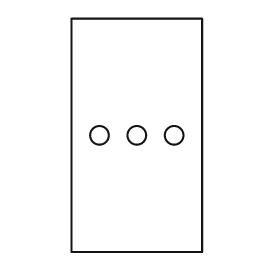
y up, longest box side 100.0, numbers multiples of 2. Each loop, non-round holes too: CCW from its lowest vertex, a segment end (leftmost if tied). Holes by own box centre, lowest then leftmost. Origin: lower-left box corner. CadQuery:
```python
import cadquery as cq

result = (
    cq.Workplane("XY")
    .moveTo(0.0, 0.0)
    .lineTo(56.0, 0.0)
    .lineTo(56.0, 100.0)
    .lineTo(0.0, 100.0)
    .close()
    .moveTo(12.0, 50.0)
    .circle(4.0)
    .moveTo(28.0, 50.0)
    .circle(4.0)
    .moveTo(44.0, 50.0)
    .circle(4.0)
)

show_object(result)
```